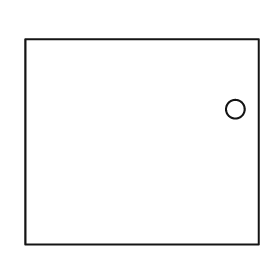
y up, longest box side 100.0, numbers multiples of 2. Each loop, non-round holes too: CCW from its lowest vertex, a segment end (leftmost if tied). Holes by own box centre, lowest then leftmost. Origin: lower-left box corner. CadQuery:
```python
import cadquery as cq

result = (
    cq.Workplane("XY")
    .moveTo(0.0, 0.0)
    .lineTo(100.0, 0.0)
    .lineTo(100.0, 88.0)
    .lineTo(0.0, 88.0)
    .close()
    .moveTo(90.0, 58.0)
    .circle(4.0)
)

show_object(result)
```